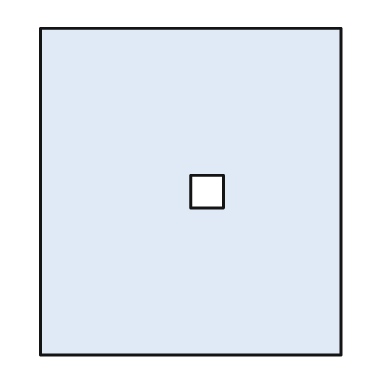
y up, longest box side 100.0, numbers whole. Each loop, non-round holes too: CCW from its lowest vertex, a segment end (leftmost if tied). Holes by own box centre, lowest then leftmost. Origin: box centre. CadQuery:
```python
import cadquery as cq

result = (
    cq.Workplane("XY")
    .moveTo(-46.0, -50.0)
    .lineTo(46.0, -50.0)
    .lineTo(46.0, 50.0)
    .lineTo(-46.0, 50.0)
    .close()
    .moveTo(0.0, -5.0)
    .lineTo(10.0, -5.0)
    .lineTo(10.0, 5.0)
    .lineTo(0.0, 5.0)
    .close()
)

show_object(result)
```